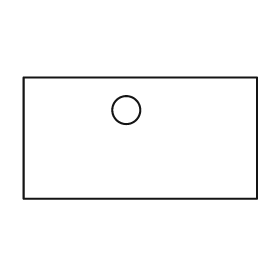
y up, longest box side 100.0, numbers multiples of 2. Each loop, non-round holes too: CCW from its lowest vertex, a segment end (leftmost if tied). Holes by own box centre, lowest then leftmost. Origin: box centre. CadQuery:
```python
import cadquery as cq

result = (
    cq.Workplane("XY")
    .moveTo(-50.0, -26.0)
    .lineTo(50.0, -26.0)
    .lineTo(50.0, 26.0)
    .lineTo(-50.0, 26.0)
    .close()
    .moveTo(-6.0, 12.0)
    .circle(6.0)
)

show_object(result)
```